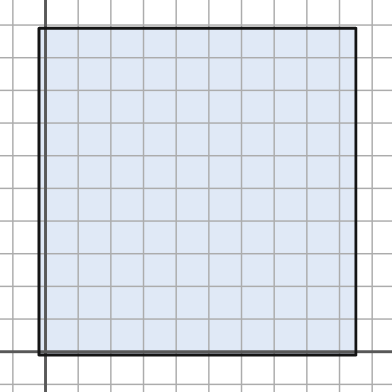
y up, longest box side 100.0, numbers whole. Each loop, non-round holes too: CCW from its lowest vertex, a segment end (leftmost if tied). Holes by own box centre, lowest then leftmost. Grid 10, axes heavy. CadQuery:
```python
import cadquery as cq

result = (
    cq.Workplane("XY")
    .moveTo(-2.0, -1.0)
    .lineTo(95.0, -1.0)
    .lineTo(95.0, 99.0)
    .lineTo(-2.0, 99.0)
    .close()
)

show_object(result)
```